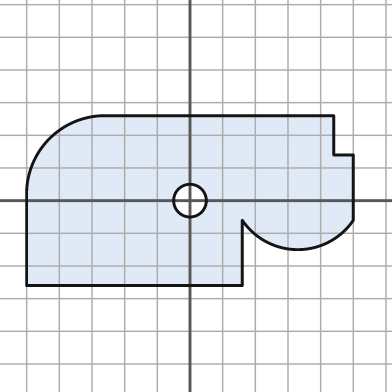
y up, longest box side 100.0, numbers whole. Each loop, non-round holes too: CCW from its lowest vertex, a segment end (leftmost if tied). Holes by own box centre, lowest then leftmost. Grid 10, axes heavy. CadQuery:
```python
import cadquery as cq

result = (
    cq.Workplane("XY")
    .moveTo(-50.0, -26.0)
    .lineTo(16.0, -26.0)
    .lineTo(16.0, -6.0)
    .threePointArc((33.0, -15.0), (50.0, -6.0))
    .lineTo(50.0, 14.0)
    .lineTo(44.0, 14.0)
    .lineTo(44.0, 26.0)
    .lineTo(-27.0, 26.0)
    .threePointArc((-43.0, 19.0), (-50.0, 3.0))
    .close()
    .moveTo(0.0, 0.0)
    .circle(5.0)
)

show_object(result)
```